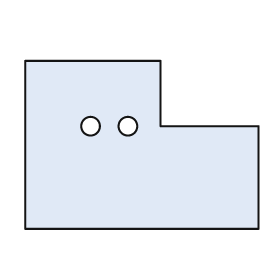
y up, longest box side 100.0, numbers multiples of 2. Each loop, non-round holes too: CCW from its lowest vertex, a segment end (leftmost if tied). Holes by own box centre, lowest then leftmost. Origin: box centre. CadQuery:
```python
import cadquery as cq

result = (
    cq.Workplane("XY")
    .moveTo(-50.0, -36.0)
    .lineTo(50.0, -36.0)
    .lineTo(50.0, 8.0)
    .lineTo(8.0, 8.0)
    .lineTo(8.0, 36.0)
    .lineTo(-50.0, 36.0)
    .close()
    .moveTo(-22.0, 8.0)
    .circle(4.0)
    .moveTo(-6.0, 8.0)
    .circle(4.0)
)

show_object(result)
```